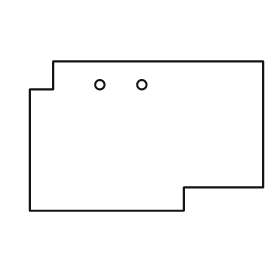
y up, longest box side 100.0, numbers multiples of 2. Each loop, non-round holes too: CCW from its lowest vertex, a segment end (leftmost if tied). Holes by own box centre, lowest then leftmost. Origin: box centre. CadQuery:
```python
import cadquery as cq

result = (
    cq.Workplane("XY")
    .moveTo(-50.0, -32.0)
    .lineTo(16.0, -32.0)
    .lineTo(16.0, -22.0)
    .lineTo(50.0, -22.0)
    .lineTo(50.0, 32.0)
    .lineTo(-40.0, 32.0)
    .lineTo(-40.0, 20.0)
    .lineTo(-50.0, 20.0)
    .close()
    .moveTo(-20.0, 22.0)
    .circle(2.0)
    .moveTo(-2.0, 22.0)
    .circle(2.0)
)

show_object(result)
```